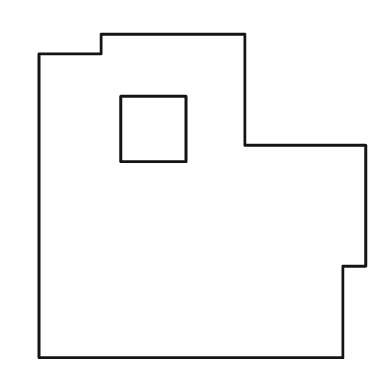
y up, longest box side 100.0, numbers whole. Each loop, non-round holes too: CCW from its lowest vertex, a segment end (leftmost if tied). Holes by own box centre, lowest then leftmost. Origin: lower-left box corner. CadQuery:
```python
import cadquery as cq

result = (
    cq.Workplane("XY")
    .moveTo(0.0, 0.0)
    .lineTo(93.0, 0.0)
    .lineTo(93.0, 28.0)
    .lineTo(100.0, 28.0)
    .lineTo(100.0, 65.0)
    .lineTo(63.0, 65.0)
    .lineTo(63.0, 99.0)
    .lineTo(19.0, 99.0)
    .lineTo(19.0, 93.0)
    .lineTo(0.0, 93.0)
    .close()
    .moveTo(25.0, 60.0)
    .lineTo(45.0, 60.0)
    .lineTo(45.0, 80.0)
    .lineTo(25.0, 80.0)
    .close()
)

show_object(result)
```